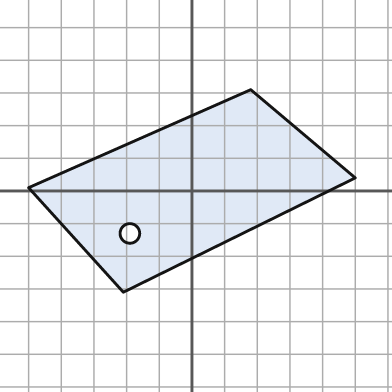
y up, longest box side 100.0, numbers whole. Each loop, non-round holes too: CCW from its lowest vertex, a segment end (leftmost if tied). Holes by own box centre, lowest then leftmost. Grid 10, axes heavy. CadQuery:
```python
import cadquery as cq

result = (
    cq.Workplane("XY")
    .moveTo(-21.0, -31.0)
    .lineTo(50.0, 4.0)
    .lineTo(18.0, 31.0)
    .lineTo(-50.0, 1.0)
    .close()
    .moveTo(-19.0, -13.0)
    .circle(3.0)
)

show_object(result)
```